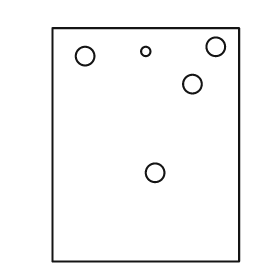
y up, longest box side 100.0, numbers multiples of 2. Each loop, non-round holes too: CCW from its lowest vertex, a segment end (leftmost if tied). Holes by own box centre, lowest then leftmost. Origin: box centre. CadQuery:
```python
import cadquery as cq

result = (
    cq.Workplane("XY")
    .moveTo(-40.0, -50.0)
    .lineTo(40.0, -50.0)
    .lineTo(40.0, 50.0)
    .lineTo(-40.0, 50.0)
    .close()
    .moveTo(4.0, -12.0)
    .circle(4.0)
    .moveTo(20.0, 26.0)
    .circle(4.0)
    .moveTo(-26.0, 38.0)
    .circle(4.0)
    .moveTo(0.0, 40.0)
    .circle(2.0)
    .moveTo(30.0, 42.0)
    .circle(4.0)
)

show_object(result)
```